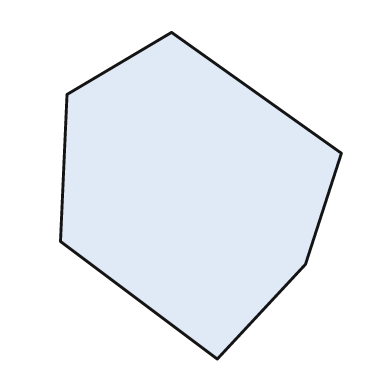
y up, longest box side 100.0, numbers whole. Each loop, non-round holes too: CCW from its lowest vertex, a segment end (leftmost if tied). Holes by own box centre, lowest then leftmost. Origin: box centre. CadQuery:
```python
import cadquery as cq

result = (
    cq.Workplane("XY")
    .moveTo(5.0, -50.0)
    .lineTo(32.0, -21.0)
    .lineTo(43.0, 13.0)
    .lineTo(-9.0, 50.0)
    .lineTo(-41.0, 31.0)
    .lineTo(-43.0, -14.0)
    .close()
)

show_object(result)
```